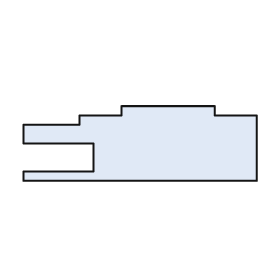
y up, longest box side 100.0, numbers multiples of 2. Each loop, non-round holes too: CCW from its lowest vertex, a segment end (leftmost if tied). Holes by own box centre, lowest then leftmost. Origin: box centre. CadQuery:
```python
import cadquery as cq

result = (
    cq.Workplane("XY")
    .moveTo(-50.0, -16.0)
    .lineTo(50.0, -16.0)
    .lineTo(50.0, 12.0)
    .lineTo(32.0, 12.0)
    .lineTo(32.0, 16.0)
    .lineTo(-8.0, 16.0)
    .lineTo(-8.0, 12.0)
    .lineTo(-26.0, 12.0)
    .lineTo(-26.0, 8.0)
    .lineTo(-50.0, 8.0)
    .lineTo(-50.0, 0.0)
    .lineTo(-20.0, 0.0)
    .lineTo(-20.0, -12.0)
    .lineTo(-50.0, -12.0)
    .close()
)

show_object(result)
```